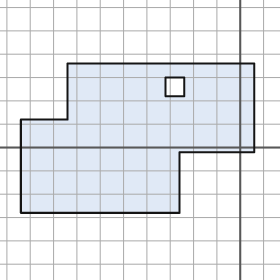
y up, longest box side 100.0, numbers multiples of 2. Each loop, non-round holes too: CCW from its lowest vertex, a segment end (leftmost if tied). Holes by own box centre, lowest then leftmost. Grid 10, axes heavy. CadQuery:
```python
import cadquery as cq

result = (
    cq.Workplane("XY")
    .moveTo(-94.0, -28.0)
    .lineTo(-26.0, -28.0)
    .lineTo(-26.0, -2.0)
    .lineTo(6.0, -2.0)
    .lineTo(6.0, 36.0)
    .lineTo(-74.0, 36.0)
    .lineTo(-74.0, 12.0)
    .lineTo(-94.0, 12.0)
    .close()
    .moveTo(-32.0, 22.0)
    .lineTo(-24.0, 22.0)
    .lineTo(-24.0, 30.0)
    .lineTo(-32.0, 30.0)
    .close()
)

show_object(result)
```